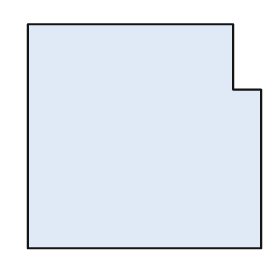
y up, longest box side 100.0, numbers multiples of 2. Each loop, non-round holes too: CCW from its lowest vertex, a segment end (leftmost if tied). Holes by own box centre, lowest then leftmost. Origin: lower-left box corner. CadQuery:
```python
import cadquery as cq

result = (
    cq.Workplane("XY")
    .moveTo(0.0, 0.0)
    .lineTo(100.0, 0.0)
    .lineTo(100.0, 68.0)
    .lineTo(88.0, 68.0)
    .lineTo(88.0, 96.0)
    .lineTo(0.0, 96.0)
    .close()
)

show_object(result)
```